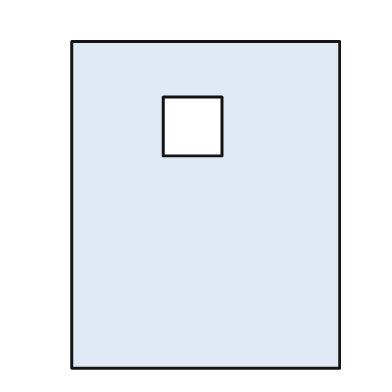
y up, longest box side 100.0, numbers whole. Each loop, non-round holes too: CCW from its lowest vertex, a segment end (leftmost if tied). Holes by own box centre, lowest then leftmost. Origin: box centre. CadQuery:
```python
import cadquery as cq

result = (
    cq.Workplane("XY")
    .moveTo(-41.0, -50.0)
    .lineTo(41.0, -50.0)
    .lineTo(41.0, 50.0)
    .lineTo(-41.0, 50.0)
    .close()
    .moveTo(-13.0, 15.0)
    .lineTo(5.0, 15.0)
    .lineTo(5.0, 33.0)
    .lineTo(-13.0, 33.0)
    .close()
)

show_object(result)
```